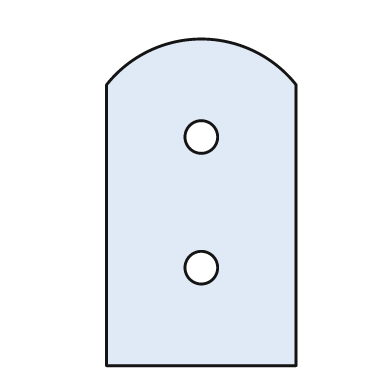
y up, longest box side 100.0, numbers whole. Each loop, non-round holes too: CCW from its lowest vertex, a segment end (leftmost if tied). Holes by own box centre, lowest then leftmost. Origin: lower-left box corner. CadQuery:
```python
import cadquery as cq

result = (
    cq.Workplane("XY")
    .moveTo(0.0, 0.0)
    .lineTo(58.0, 0.0)
    .lineTo(58.0, 86.0)
    .threePointArc((29.0, 100.0), (0.0, 86.0))
    .close()
    .moveTo(29.0, 30.0)
    .circle(5.0)
    .moveTo(29.0, 70.0)
    .circle(5.0)
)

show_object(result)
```